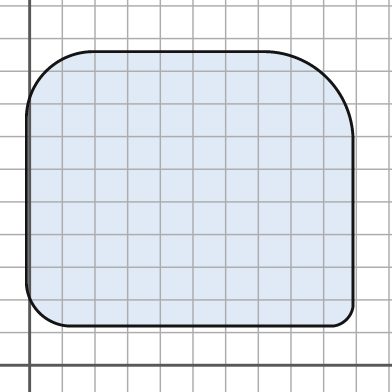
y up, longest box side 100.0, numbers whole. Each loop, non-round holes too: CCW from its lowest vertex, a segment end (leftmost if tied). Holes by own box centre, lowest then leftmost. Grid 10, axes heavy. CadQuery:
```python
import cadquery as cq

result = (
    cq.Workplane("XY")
    .moveTo(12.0, 12.0)
    .lineTo(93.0, 12.0)
    .threePointArc((97.0, 14.0), (99.0, 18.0))
    .lineTo(99.0, 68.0)
    .threePointArc((91.0, 88.0), (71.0, 96.0))
    .lineTo(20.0, 96.0)
    .threePointArc((5.0, 90.0), (-1.0, 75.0))
    .lineTo(-1.0, 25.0)
    .threePointArc((3.0, 16.0), (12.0, 12.0))
    .close()
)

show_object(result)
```